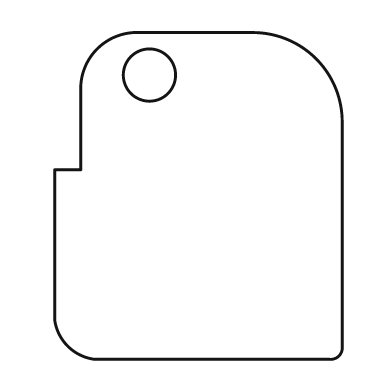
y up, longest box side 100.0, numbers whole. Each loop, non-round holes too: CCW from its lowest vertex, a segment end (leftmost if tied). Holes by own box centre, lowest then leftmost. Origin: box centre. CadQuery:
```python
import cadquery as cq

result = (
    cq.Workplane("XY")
    .moveTo(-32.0, -50.0)
    .lineTo(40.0, -50.0)
    .threePointArc((43.0, -49.0), (44.0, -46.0))
    .lineTo(44.0, 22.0)
    .threePointArc((36.0, 42.0), (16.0, 50.0))
    .lineTo(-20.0, 50.0)
    .threePointArc((-31.0, 45.0), (-36.0, 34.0))
    .lineTo(-36.0, 8.0)
    .lineTo(-44.0, 8.0)
    .lineTo(-44.0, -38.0)
    .threePointArc((-40.0, -46.0), (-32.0, -50.0))
    .close()
    .moveTo(-15.0, 37.0)
    .circle(8.0)
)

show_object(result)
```